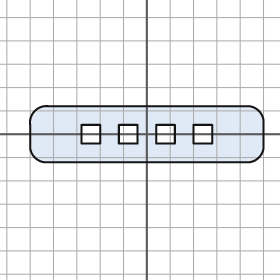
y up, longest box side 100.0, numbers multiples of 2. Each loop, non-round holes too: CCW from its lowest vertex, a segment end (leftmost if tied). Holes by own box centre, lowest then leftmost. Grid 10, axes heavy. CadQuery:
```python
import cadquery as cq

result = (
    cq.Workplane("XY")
    .moveTo(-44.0, -12.0)
    .lineTo(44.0, -12.0)
    .threePointArc((48.0, -10.0), (50.0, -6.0))
    .lineTo(50.0, 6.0)
    .threePointArc((48.0, 10.0), (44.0, 12.0))
    .lineTo(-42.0, 12.0)
    .threePointArc((-48.0, 10.0), (-50.0, 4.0))
    .lineTo(-50.0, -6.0)
    .threePointArc((-48.0, -10.0), (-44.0, -12.0))
    .close()
    .moveTo(-28.0, -4.0)
    .lineTo(-20.0, -4.0)
    .lineTo(-20.0, 4.0)
    .lineTo(-28.0, 4.0)
    .close()
    .moveTo(-12.0, -4.0)
    .lineTo(-4.0, -4.0)
    .lineTo(-4.0, 4.0)
    .lineTo(-12.0, 4.0)
    .close()
    .moveTo(4.0, -4.0)
    .lineTo(12.0, -4.0)
    .lineTo(12.0, 4.0)
    .lineTo(4.0, 4.0)
    .close()
    .moveTo(20.0, -4.0)
    .lineTo(28.0, -4.0)
    .lineTo(28.0, 4.0)
    .lineTo(20.0, 4.0)
    .close()
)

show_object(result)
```